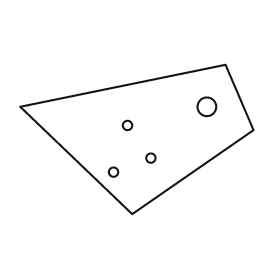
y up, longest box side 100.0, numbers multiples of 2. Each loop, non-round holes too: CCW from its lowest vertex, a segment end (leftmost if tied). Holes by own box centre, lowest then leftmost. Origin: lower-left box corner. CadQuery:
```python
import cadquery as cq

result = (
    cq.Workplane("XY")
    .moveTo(48.0, 0.0)
    .lineTo(100.0, 36.0)
    .lineTo(88.0, 64.0)
    .lineTo(0.0, 46.0)
    .close()
    .moveTo(40.0, 18.0)
    .circle(2.0)
    .moveTo(56.0, 24.0)
    .circle(2.0)
    .moveTo(46.0, 38.0)
    .circle(2.0)
    .moveTo(80.0, 46.0)
    .circle(4.0)
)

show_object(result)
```